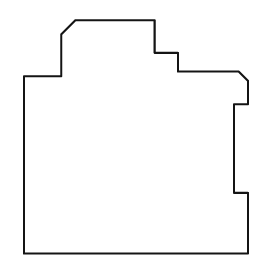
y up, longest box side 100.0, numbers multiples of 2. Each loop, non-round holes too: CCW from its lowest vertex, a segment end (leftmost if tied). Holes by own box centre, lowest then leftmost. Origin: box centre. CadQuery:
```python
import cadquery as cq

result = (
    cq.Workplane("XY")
    .moveTo(-48.0, -50.0)
    .lineTo(48.0, -50.0)
    .lineTo(48.0, -24.0)
    .lineTo(42.0, -24.0)
    .lineTo(42.0, 14.0)
    .lineTo(48.0, 14.0)
    .lineTo(48.0, 24.0)
    .lineTo(44.0, 28.0)
    .lineTo(18.0, 28.0)
    .lineTo(18.0, 36.0)
    .lineTo(8.0, 36.0)
    .lineTo(8.0, 50.0)
    .lineTo(-26.0, 50.0)
    .lineTo(-32.0, 44.0)
    .lineTo(-32.0, 26.0)
    .lineTo(-48.0, 26.0)
    .close()
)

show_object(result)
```